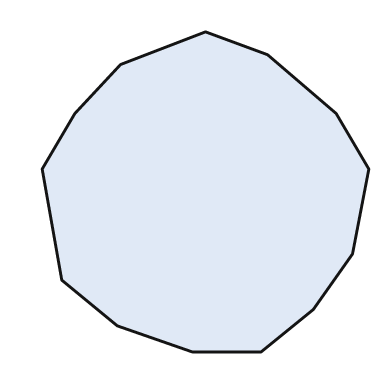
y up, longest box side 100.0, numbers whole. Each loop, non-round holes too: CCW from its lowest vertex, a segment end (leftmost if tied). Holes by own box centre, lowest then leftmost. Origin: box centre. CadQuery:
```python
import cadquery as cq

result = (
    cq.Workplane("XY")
    .moveTo(-4.0, -49.0)
    .lineTo(17.0, -49.0)
    .lineTo(33.0, -36.0)
    .lineTo(45.0, -19.0)
    .lineTo(50.0, 7.0)
    .lineTo(40.0, 24.0)
    .lineTo(19.0, 42.0)
    .lineTo(0.0, 49.0)
    .lineTo(-26.0, 39.0)
    .lineTo(-40.0, 24.0)
    .lineTo(-50.0, 7.0)
    .lineTo(-44.0, -27.0)
    .lineTo(-27.0, -41.0)
    .close()
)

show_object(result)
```